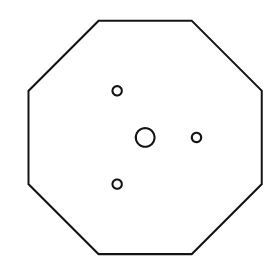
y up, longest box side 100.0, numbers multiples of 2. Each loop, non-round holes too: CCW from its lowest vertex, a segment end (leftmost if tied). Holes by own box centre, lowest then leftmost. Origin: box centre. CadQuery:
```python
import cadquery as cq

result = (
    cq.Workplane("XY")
    .moveTo(-20.0, -50.0)
    .lineTo(20.0, -50.0)
    .lineTo(50.0, -20.0)
    .lineTo(50.0, 20.0)
    .lineTo(20.0, 50.0)
    .lineTo(-20.0, 50.0)
    .lineTo(-50.0, 20.0)
    .lineTo(-50.0, -20.0)
    .close()
    .moveTo(-12.0, -20.0)
    .circle(2.0)
    .moveTo(0.0, 0.0)
    .circle(4.0)
    .moveTo(22.0, 0.0)
    .circle(2.0)
    .moveTo(-12.0, 20.0)
    .circle(2.0)
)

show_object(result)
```